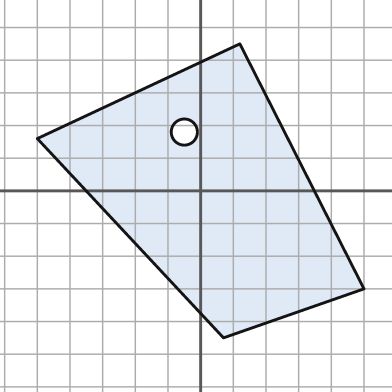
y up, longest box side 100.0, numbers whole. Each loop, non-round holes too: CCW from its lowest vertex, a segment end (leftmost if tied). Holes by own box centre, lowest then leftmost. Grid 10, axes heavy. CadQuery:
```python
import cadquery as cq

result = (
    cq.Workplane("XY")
    .moveTo(7.0, -45.0)
    .lineTo(50.0, -30.0)
    .lineTo(12.0, 45.0)
    .lineTo(-50.0, 16.0)
    .close()
    .moveTo(-5.0, 18.0)
    .circle(4.0)
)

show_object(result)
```